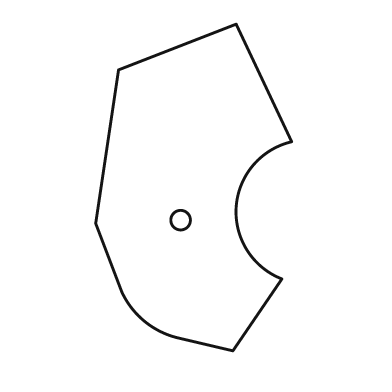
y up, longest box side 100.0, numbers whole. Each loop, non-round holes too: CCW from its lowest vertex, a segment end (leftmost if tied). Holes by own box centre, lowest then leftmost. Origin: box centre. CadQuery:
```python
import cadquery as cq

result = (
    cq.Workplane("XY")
    .moveTo(12.0, -50.0)
    .lineTo(27.0, -28.0)
    .threePointArc((13.0, -6.0), (30.0, 14.0))
    .lineTo(13.0, 50.0)
    .lineTo(-23.0, 36.0)
    .lineTo(-30.0, -11.0)
    .lineTo(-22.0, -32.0)
    .threePointArc((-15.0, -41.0), (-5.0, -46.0))
    .close()
    .moveTo(-4.0, -10.0)
    .circle(3.0)
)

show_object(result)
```